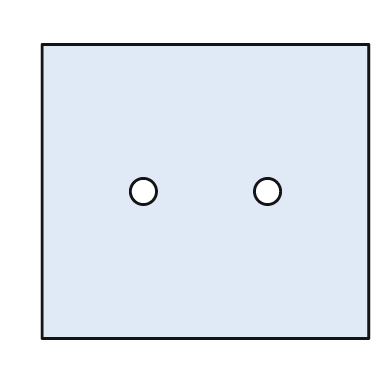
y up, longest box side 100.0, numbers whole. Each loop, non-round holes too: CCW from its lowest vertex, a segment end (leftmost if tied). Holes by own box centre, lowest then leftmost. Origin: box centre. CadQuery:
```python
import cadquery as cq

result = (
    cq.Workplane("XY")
    .moveTo(-50.0, -45.0)
    .lineTo(50.0, -45.0)
    .lineTo(50.0, 45.0)
    .lineTo(-50.0, 45.0)
    .close()
    .moveTo(-19.0, 0.0)
    .circle(4.0)
    .moveTo(19.0, 0.0)
    .circle(4.0)
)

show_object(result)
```